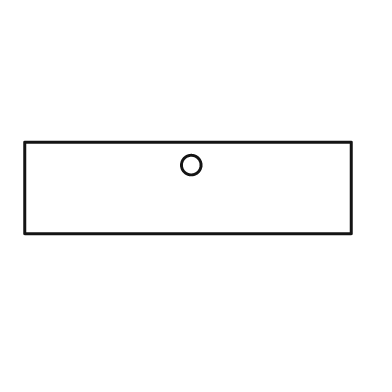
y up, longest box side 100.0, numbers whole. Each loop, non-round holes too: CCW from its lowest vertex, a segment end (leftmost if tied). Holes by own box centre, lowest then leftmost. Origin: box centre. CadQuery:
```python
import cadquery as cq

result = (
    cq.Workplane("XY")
    .moveTo(-50.0, -14.0)
    .lineTo(50.0, -14.0)
    .lineTo(50.0, 14.0)
    .lineTo(-50.0, 14.0)
    .close()
    .moveTo(1.0, 7.0)
    .circle(3.0)
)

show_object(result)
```